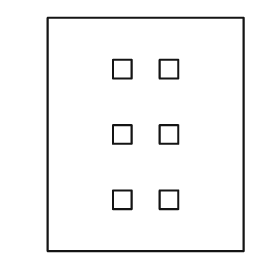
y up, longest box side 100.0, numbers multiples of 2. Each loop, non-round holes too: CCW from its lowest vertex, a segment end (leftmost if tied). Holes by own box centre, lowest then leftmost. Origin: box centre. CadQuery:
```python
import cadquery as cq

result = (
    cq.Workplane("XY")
    .moveTo(-42.0, -50.0)
    .lineTo(42.0, -50.0)
    .lineTo(42.0, 50.0)
    .lineTo(-42.0, 50.0)
    .close()
    .moveTo(-14.0, -32.0)
    .lineTo(-6.0, -32.0)
    .lineTo(-6.0, -24.0)
    .lineTo(-14.0, -24.0)
    .close()
    .moveTo(6.0, -32.0)
    .lineTo(14.0, -32.0)
    .lineTo(14.0, -24.0)
    .lineTo(6.0, -24.0)
    .close()
    .moveTo(-14.0, -4.0)
    .lineTo(-6.0, -4.0)
    .lineTo(-6.0, 4.0)
    .lineTo(-14.0, 4.0)
    .close()
    .moveTo(6.0, -4.0)
    .lineTo(14.0, -4.0)
    .lineTo(14.0, 4.0)
    .lineTo(6.0, 4.0)
    .close()
    .moveTo(-14.0, 24.0)
    .lineTo(-6.0, 24.0)
    .lineTo(-6.0, 32.0)
    .lineTo(-14.0, 32.0)
    .close()
    .moveTo(6.0, 24.0)
    .lineTo(14.0, 24.0)
    .lineTo(14.0, 32.0)
    .lineTo(6.0, 32.0)
    .close()
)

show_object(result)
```